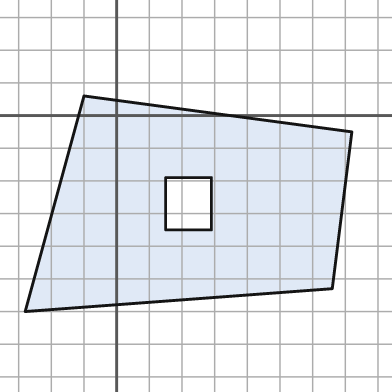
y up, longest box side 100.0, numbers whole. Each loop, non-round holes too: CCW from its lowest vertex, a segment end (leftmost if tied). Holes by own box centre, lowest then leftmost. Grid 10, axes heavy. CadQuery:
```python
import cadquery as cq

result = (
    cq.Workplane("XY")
    .moveTo(-28.0, -60.0)
    .lineTo(66.0, -53.0)
    .lineTo(72.0, -5.0)
    .lineTo(-10.0, 6.0)
    .close()
    .moveTo(15.0, -35.0)
    .lineTo(29.0, -35.0)
    .lineTo(29.0, -19.0)
    .lineTo(15.0, -19.0)
    .close()
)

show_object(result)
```